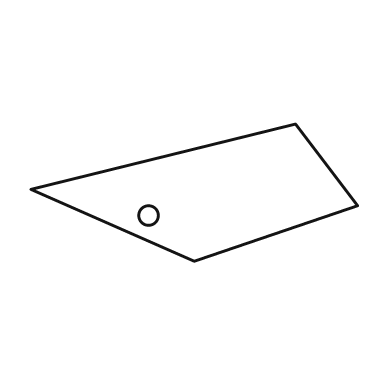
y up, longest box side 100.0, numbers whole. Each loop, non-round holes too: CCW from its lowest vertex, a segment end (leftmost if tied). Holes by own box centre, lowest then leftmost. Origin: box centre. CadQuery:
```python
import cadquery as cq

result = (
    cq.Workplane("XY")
    .moveTo(0.0, -21.0)
    .lineTo(50.0, -4.0)
    .lineTo(31.0, 21.0)
    .lineTo(-50.0, 1.0)
    .close()
    .moveTo(-14.0, -7.0)
    .circle(3.0)
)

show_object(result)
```